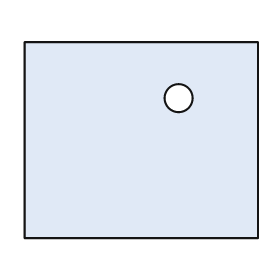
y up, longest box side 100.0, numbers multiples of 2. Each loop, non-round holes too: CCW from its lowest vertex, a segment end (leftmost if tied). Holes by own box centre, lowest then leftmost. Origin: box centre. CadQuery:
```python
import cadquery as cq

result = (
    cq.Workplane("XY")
    .moveTo(-50.0, -42.0)
    .lineTo(50.0, -42.0)
    .lineTo(50.0, 42.0)
    .lineTo(-50.0, 42.0)
    .close()
    .moveTo(16.0, 18.0)
    .circle(6.0)
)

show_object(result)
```